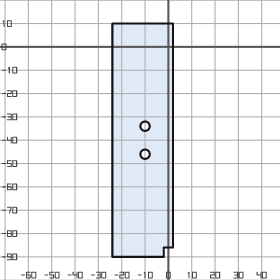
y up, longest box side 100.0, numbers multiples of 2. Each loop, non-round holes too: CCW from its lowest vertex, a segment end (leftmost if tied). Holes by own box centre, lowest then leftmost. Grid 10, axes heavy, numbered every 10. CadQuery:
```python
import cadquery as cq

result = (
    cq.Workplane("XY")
    .moveTo(-24.0, -90.0)
    .lineTo(-2.0, -90.0)
    .lineTo(-2.0, -86.0)
    .lineTo(2.0, -86.0)
    .lineTo(2.0, 10.0)
    .lineTo(-24.0, 10.0)
    .close()
    .moveTo(-10.0, -46.0)
    .circle(2.0)
    .moveTo(-10.0, -34.0)
    .circle(2.0)
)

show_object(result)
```